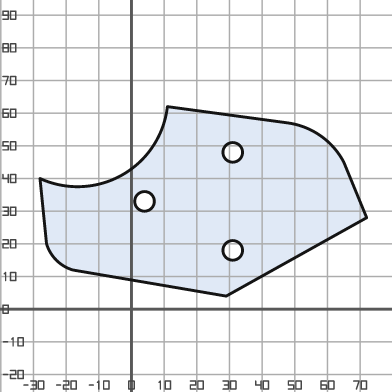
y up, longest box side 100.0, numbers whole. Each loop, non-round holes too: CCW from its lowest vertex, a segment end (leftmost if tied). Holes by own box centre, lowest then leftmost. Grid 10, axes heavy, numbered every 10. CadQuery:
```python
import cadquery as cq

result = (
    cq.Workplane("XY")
    .moveTo(29.0, 4.0)
    .lineTo(72.0, 28.0)
    .lineTo(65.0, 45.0)
    .threePointArc((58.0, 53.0), (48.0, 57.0))
    .lineTo(11.0, 62.0)
    .threePointArc((-3.0, 41.0), (-28.0, 40.0))
    .lineTo(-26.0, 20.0)
    .threePointArc((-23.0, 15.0), (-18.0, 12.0))
    .close()
    .moveTo(31.0, 18.0)
    .circle(3.0)
    .moveTo(4.0, 33.0)
    .circle(3.0)
    .moveTo(31.0, 48.0)
    .circle(3.0)
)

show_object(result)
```